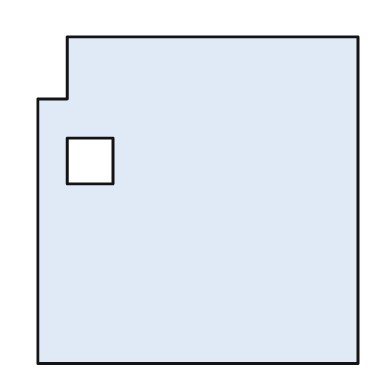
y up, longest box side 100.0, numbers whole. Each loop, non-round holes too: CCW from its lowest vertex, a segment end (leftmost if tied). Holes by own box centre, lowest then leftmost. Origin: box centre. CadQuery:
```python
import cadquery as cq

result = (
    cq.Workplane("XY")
    .moveTo(-49.0, -50.0)
    .lineTo(49.0, -50.0)
    .lineTo(49.0, 50.0)
    .lineTo(-40.0, 50.0)
    .lineTo(-40.0, 31.0)
    .lineTo(-49.0, 31.0)
    .close()
    .moveTo(-40.0, 5.0)
    .lineTo(-26.0, 5.0)
    .lineTo(-26.0, 19.0)
    .lineTo(-40.0, 19.0)
    .close()
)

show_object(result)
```